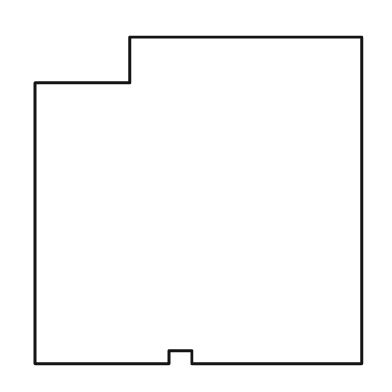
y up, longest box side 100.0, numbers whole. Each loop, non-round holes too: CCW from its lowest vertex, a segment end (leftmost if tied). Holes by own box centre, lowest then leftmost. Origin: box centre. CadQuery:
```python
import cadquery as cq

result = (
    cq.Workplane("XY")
    .moveTo(-50.0, -50.0)
    .lineTo(-9.0, -50.0)
    .lineTo(-9.0, -46.0)
    .lineTo(-2.0, -46.0)
    .lineTo(-2.0, -50.0)
    .lineTo(50.0, -50.0)
    .lineTo(50.0, 50.0)
    .lineTo(-21.0, 50.0)
    .lineTo(-21.0, 36.0)
    .lineTo(-50.0, 36.0)
    .close()
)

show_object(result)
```